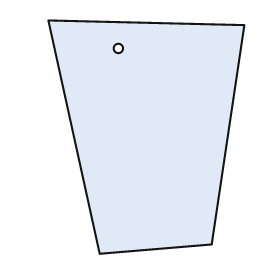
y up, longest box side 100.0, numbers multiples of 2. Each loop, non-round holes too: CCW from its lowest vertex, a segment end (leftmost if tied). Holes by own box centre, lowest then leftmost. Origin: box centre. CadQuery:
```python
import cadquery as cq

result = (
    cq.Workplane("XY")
    .moveTo(-20.0, -50.0)
    .lineTo(28.0, -46.0)
    .lineTo(42.0, 48.0)
    .lineTo(-42.0, 50.0)
    .close()
    .moveTo(-12.0, 38.0)
    .circle(2.0)
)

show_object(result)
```